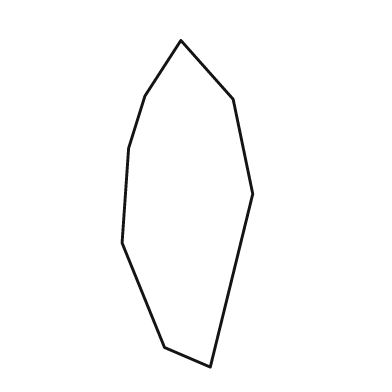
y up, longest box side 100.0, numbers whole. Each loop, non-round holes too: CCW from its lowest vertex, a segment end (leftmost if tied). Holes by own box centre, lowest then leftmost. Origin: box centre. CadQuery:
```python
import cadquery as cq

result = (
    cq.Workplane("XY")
    .moveTo(7.0, -50.0)
    .lineTo(20.0, 3.0)
    .lineTo(14.0, 32.0)
    .lineTo(-2.0, 50.0)
    .lineTo(-13.0, 33.0)
    .lineTo(-18.0, 17.0)
    .lineTo(-20.0, -12.0)
    .lineTo(-7.0, -44.0)
    .close()
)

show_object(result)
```